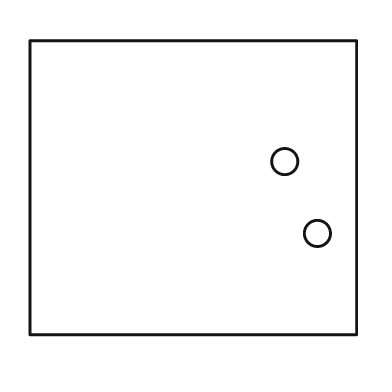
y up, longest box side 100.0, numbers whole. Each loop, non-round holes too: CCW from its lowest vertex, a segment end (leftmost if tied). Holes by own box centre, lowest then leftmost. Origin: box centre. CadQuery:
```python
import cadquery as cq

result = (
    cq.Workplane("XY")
    .moveTo(-50.0, -45.0)
    .lineTo(50.0, -45.0)
    .lineTo(50.0, 45.0)
    .lineTo(-50.0, 45.0)
    .close()
    .moveTo(38.0, -14.0)
    .circle(4.0)
    .moveTo(28.0, 8.0)
    .circle(4.0)
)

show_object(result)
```